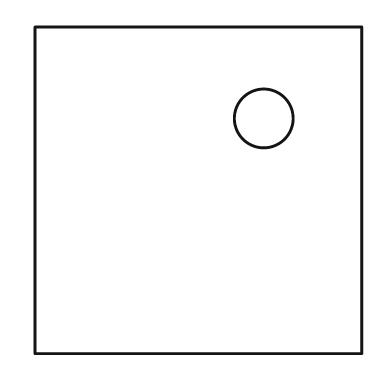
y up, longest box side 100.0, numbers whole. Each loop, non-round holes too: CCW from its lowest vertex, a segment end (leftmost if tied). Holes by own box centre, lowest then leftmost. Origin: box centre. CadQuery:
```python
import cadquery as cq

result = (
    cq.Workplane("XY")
    .moveTo(-50.0, -50.0)
    .lineTo(50.0, -50.0)
    .lineTo(50.0, 50.0)
    .lineTo(-50.0, 50.0)
    .close()
    .moveTo(20.0, 22.0)
    .circle(9.0)
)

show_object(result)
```